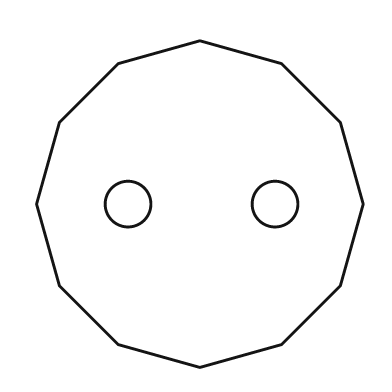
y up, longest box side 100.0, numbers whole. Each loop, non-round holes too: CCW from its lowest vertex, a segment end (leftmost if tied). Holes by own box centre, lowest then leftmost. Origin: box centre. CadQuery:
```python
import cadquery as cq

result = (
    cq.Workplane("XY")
    .moveTo(0.0, -50.0)
    .lineTo(25.0, -43.0)
    .lineTo(43.0, -25.0)
    .lineTo(50.0, 0.0)
    .lineTo(43.0, 25.0)
    .lineTo(25.0, 43.0)
    .lineTo(0.0, 50.0)
    .lineTo(-25.0, 43.0)
    .lineTo(-43.0, 25.0)
    .lineTo(-50.0, 0.0)
    .lineTo(-43.0, -25.0)
    .lineTo(-25.0, -43.0)
    .close()
    .moveTo(-22.0, 0.0)
    .circle(7.0)
    .moveTo(23.0, 0.0)
    .circle(7.0)
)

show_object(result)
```